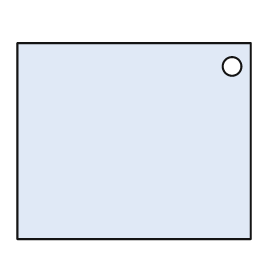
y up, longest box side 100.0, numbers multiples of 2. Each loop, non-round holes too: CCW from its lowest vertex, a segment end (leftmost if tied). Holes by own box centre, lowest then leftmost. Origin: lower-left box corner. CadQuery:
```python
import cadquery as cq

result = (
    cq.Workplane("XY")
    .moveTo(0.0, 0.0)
    .lineTo(100.0, 0.0)
    .lineTo(100.0, 84.0)
    .lineTo(0.0, 84.0)
    .close()
    .moveTo(92.0, 74.0)
    .circle(4.0)
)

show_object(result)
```